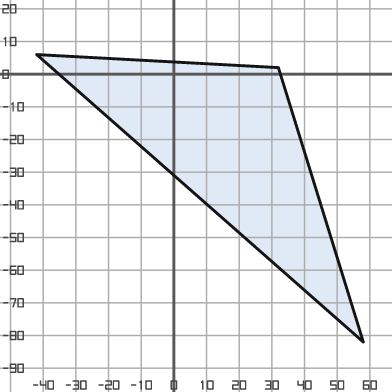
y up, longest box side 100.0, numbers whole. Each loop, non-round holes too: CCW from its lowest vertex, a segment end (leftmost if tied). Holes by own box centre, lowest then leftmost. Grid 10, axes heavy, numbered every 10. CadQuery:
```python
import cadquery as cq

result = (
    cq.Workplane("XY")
    .moveTo(58.0, -82.0)
    .lineTo(32.0, 2.0)
    .lineTo(-42.0, 6.0)
    .close()
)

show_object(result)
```